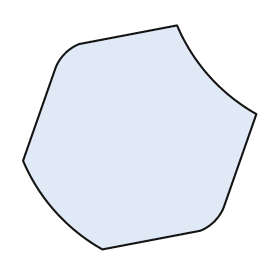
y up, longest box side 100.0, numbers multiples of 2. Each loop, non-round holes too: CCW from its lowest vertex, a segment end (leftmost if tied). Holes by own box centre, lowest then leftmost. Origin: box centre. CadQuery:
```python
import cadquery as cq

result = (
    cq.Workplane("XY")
    .moveTo(-16.0, -48.0)
    .lineTo(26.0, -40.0)
    .threePointArc((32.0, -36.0), (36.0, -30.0))
    .lineTo(50.0, 10.0)
    .threePointArc((30.0, 26.0), (16.0, 48.0))
    .lineTo(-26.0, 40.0)
    .threePointArc((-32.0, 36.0), (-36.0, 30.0))
    .lineTo(-50.0, -10.0)
    .threePointArc((-36.0, -32.0), (-16.0, -48.0))
    .close()
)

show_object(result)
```